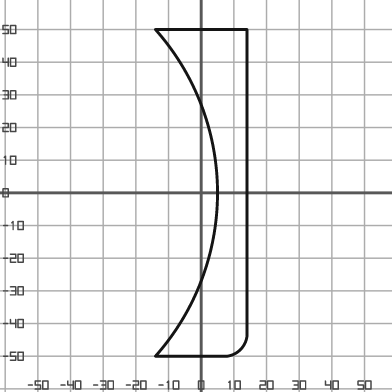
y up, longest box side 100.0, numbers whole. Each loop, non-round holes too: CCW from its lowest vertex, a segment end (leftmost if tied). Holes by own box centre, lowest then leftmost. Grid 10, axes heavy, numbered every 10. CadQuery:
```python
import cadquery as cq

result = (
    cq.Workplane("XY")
    .moveTo(-14.0, -50.0)
    .lineTo(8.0, -50.0)
    .threePointArc((12.0, -48.0), (14.0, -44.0))
    .lineTo(14.0, 50.0)
    .lineTo(-14.0, 50.0)
    .threePointArc((5.0, 0.0), (-14.0, -50.0))
    .close()
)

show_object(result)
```